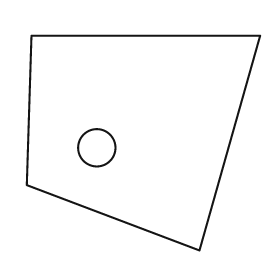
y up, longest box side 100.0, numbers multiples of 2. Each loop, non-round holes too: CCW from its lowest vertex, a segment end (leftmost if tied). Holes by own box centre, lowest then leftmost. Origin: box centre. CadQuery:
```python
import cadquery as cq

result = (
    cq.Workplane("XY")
    .moveTo(24.0, -46.0)
    .lineTo(50.0, 46.0)
    .lineTo(-48.0, 46.0)
    .lineTo(-50.0, -18.0)
    .close()
    .moveTo(-20.0, -2.0)
    .circle(8.0)
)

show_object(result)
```